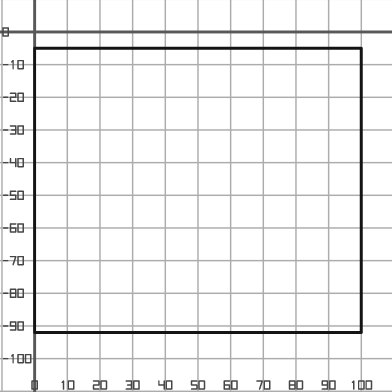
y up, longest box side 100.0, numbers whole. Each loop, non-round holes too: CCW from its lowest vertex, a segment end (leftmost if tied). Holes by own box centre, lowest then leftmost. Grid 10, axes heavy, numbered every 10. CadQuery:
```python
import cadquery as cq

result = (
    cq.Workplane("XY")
    .moveTo(0.0, -92.0)
    .lineTo(100.0, -92.0)
    .lineTo(100.0, -5.0)
    .lineTo(0.0, -5.0)
    .close()
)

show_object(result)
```